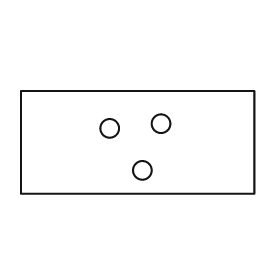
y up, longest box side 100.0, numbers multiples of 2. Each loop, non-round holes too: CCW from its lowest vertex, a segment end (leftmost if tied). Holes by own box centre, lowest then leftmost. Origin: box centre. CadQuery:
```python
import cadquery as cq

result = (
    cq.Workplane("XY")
    .moveTo(-50.0, -22.0)
    .lineTo(50.0, -22.0)
    .lineTo(50.0, 22.0)
    .lineTo(-50.0, 22.0)
    .close()
    .moveTo(2.0, -12.0)
    .circle(4.0)
    .moveTo(-12.0, 6.0)
    .circle(4.0)
    .moveTo(10.0, 8.0)
    .circle(4.0)
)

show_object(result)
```